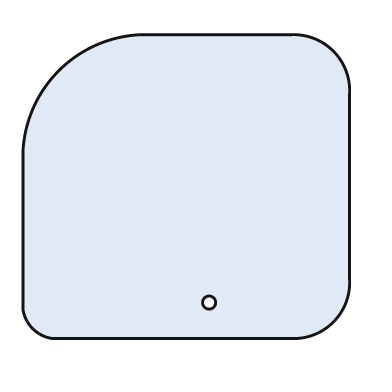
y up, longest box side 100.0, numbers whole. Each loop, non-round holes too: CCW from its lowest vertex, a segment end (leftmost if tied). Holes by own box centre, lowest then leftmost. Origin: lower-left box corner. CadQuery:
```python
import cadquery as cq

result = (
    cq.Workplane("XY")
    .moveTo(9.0, 0.0)
    .lineTo(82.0, 0.0)
    .threePointArc((95.0, 5.0), (100.0, 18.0))
    .lineTo(100.0, 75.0)
    .threePointArc((95.0, 88.0), (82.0, 93.0))
    .lineTo(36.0, 93.0)
    .threePointArc((11.0, 82.0), (0.0, 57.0))
    .lineTo(0.0, 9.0)
    .threePointArc((3.0, 3.0), (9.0, 0.0))
    .close()
    .moveTo(57.0, 11.0)
    .circle(2.0)
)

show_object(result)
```